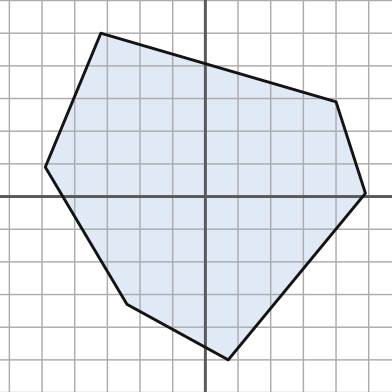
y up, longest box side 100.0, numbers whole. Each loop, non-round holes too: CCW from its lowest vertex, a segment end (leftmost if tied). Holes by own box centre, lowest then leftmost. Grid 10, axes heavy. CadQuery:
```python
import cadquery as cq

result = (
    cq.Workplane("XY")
    .moveTo(7.0, -50.0)
    .lineTo(49.0, 1.0)
    .lineTo(40.0, 29.0)
    .lineTo(-32.0, 50.0)
    .lineTo(-49.0, 9.0)
    .lineTo(-24.0, -33.0)
    .close()
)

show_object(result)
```